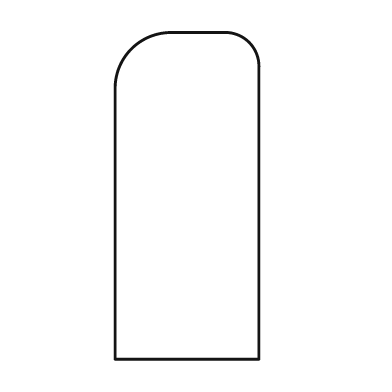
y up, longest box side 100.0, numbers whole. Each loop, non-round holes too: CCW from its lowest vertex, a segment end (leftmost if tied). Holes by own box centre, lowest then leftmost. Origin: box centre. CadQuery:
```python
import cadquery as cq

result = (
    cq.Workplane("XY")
    .moveTo(-22.0, -50.0)
    .lineTo(22.0, -50.0)
    .lineTo(22.0, 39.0)
    .threePointArc((19.0, 47.0), (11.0, 50.0))
    .lineTo(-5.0, 50.0)
    .threePointArc((-17.0, 45.0), (-22.0, 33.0))
    .close()
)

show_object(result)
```